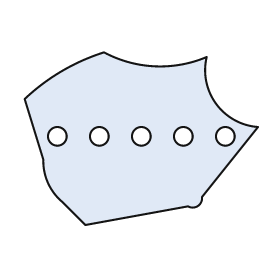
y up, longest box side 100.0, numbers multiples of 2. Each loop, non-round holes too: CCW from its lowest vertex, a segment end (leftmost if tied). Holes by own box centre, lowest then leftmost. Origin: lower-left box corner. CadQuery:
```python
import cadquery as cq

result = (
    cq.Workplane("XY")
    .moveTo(26.0, 0.0)
    .lineTo(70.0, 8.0)
    .threePointArc((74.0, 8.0), (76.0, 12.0))
    .lineTo(100.0, 42.0)
    .threePointArc((82.0, 52.0), (78.0, 72.0))
    .threePointArc((56.0, 68.0), (34.0, 74.0))
    .threePointArc((16.0, 66.0), (0.0, 54.0))
    .lineTo(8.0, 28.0)
    .threePointArc((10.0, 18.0), (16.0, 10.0))
    .close()
    .moveTo(14.0, 38.0)
    .circle(4.0)
    .moveTo(32.0, 38.0)
    .circle(4.0)
    .moveTo(50.0, 38.0)
    .circle(4.0)
    .moveTo(68.0, 38.0)
    .circle(4.0)
    .moveTo(86.0, 38.0)
    .circle(4.0)
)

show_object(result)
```